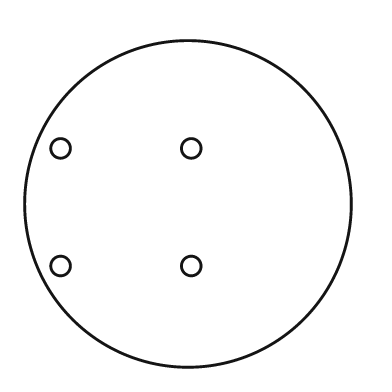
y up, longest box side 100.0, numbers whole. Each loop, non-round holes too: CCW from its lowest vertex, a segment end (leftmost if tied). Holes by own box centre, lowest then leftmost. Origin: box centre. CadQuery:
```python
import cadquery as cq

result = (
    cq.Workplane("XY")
    .moveTo(0.0, 0.0)
    .circle(50.0)
    .moveTo(-39.0, -19.0)
    .circle(3.0)
    .moveTo(1.0, -19.0)
    .circle(3.0)
    .moveTo(-39.0, 17.0)
    .circle(3.0)
    .moveTo(1.0, 17.0)
    .circle(3.0)
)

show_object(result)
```